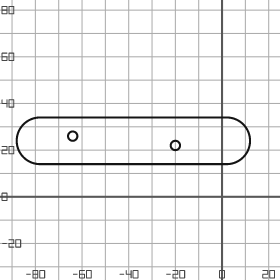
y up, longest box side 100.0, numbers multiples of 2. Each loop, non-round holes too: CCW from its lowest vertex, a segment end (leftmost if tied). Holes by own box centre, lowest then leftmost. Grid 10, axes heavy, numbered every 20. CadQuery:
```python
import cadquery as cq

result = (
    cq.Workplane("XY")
    .moveTo(-78.0, 14.0)
    .lineTo(2.0, 14.0)
    .threePointArc((12.0, 24.0), (2.0, 34.0))
    .lineTo(-78.0, 34.0)
    .threePointArc((-88.0, 24.0), (-78.0, 14.0))
    .close()
    .moveTo(-20.0, 22.0)
    .circle(2.0)
    .moveTo(-64.0, 26.0)
    .circle(2.0)
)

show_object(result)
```